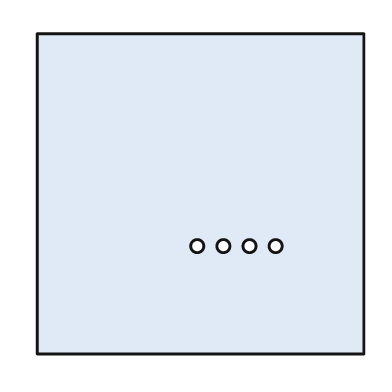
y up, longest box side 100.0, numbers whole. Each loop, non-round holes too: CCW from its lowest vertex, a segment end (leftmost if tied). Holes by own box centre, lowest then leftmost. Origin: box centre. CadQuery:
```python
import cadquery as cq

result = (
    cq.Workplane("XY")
    .moveTo(-50.0, -49.0)
    .lineTo(50.0, -49.0)
    .lineTo(50.0, 49.0)
    .lineTo(-50.0, 49.0)
    .close()
    .moveTo(-1.0, -16.0)
    .circle(2.0)
    .moveTo(7.0, -16.0)
    .circle(2.0)
    .moveTo(15.0, -16.0)
    .circle(2.0)
    .moveTo(23.0, -16.0)
    .circle(2.0)
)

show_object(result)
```